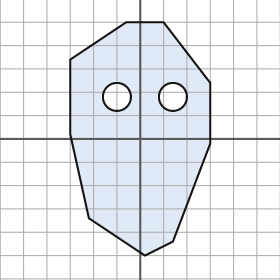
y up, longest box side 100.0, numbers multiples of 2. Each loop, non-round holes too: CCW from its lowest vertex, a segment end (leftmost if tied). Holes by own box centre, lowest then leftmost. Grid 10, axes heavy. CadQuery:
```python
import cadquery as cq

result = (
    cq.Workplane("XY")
    .moveTo(2.0, -50.0)
    .lineTo(14.0, -44.0)
    .lineTo(30.0, -2.0)
    .lineTo(30.0, 24.0)
    .lineTo(10.0, 50.0)
    .lineTo(-6.0, 50.0)
    .lineTo(-30.0, 34.0)
    .lineTo(-30.0, 2.0)
    .lineTo(-22.0, -34.0)
    .close()
    .moveTo(-10.0, 18.0)
    .circle(6.0)
    .moveTo(14.0, 18.0)
    .circle(6.0)
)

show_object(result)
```